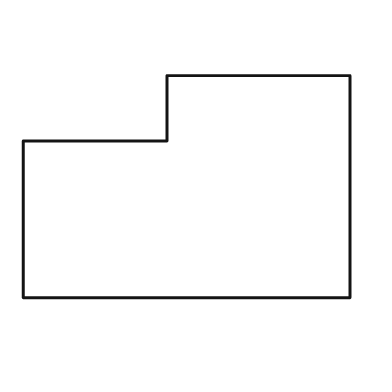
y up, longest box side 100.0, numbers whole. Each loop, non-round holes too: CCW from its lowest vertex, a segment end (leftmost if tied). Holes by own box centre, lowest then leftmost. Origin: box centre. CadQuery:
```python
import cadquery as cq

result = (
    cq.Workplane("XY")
    .moveTo(-50.0, -34.0)
    .lineTo(50.0, -34.0)
    .lineTo(50.0, 34.0)
    .lineTo(-6.0, 34.0)
    .lineTo(-6.0, 14.0)
    .lineTo(-50.0, 14.0)
    .close()
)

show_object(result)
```